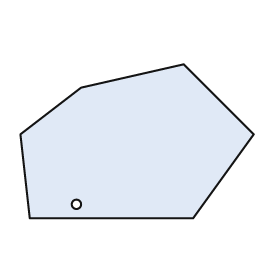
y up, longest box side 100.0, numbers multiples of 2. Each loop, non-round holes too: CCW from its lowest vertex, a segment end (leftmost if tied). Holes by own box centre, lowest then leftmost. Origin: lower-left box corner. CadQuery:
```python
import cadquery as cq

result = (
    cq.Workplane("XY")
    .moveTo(4.0, 0.0)
    .lineTo(74.0, 0.0)
    .lineTo(100.0, 36.0)
    .lineTo(70.0, 66.0)
    .lineTo(26.0, 56.0)
    .lineTo(0.0, 36.0)
    .close()
    .moveTo(24.0, 6.0)
    .circle(2.0)
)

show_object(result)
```